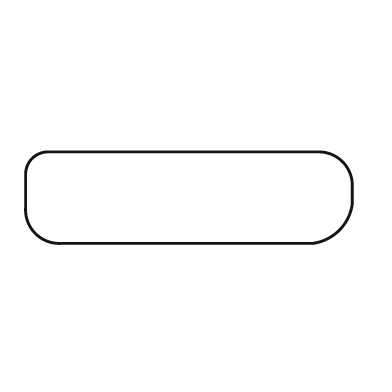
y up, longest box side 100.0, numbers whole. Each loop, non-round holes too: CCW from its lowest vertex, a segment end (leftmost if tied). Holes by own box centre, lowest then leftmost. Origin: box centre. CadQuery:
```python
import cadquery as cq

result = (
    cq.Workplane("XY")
    .moveTo(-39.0, -14.0)
    .lineTo(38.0, -14.0)
    .threePointArc((46.0, -10.0), (50.0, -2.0))
    .lineTo(50.0, 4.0)
    .threePointArc((47.0, 11.0), (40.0, 14.0))
    .lineTo(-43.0, 14.0)
    .threePointArc((-48.0, 12.0), (-50.0, 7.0))
    .lineTo(-50.0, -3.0)
    .threePointArc((-47.0, -11.0), (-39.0, -14.0))
    .close()
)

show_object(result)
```